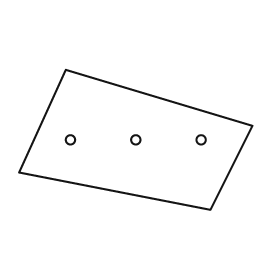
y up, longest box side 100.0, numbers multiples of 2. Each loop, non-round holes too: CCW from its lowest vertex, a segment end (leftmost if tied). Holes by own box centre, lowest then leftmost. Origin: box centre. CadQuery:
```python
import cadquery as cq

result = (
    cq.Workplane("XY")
    .moveTo(32.0, -30.0)
    .lineTo(50.0, 6.0)
    .lineTo(-30.0, 30.0)
    .lineTo(-50.0, -14.0)
    .close()
    .moveTo(-28.0, 0.0)
    .circle(2.0)
    .moveTo(0.0, 0.0)
    .circle(2.0)
    .moveTo(28.0, 0.0)
    .circle(2.0)
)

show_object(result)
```